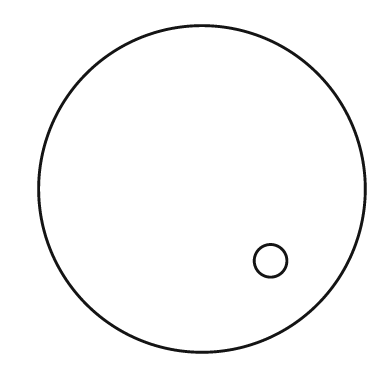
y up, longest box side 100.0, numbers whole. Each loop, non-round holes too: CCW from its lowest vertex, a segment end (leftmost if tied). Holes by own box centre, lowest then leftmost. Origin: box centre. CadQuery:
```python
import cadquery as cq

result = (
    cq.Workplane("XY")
    .moveTo(0.0, 0.0)
    .circle(50.0)
    .moveTo(21.0, -22.0)
    .circle(5.0)
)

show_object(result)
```